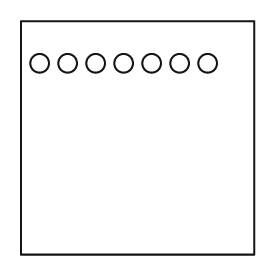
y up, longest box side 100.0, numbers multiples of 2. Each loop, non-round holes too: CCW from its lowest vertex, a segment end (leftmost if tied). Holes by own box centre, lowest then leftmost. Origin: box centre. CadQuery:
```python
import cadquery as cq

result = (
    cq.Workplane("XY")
    .moveTo(-50.0, -50.0)
    .lineTo(50.0, -50.0)
    .lineTo(50.0, 50.0)
    .lineTo(-50.0, 50.0)
    .close()
    .moveTo(-42.0, 32.0)
    .circle(4.0)
    .moveTo(-30.0, 32.0)
    .circle(4.0)
    .moveTo(-18.0, 32.0)
    .circle(4.0)
    .moveTo(-6.0, 32.0)
    .circle(4.0)
    .moveTo(6.0, 32.0)
    .circle(4.0)
    .moveTo(18.0, 32.0)
    .circle(4.0)
    .moveTo(30.0, 32.0)
    .circle(4.0)
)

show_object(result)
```